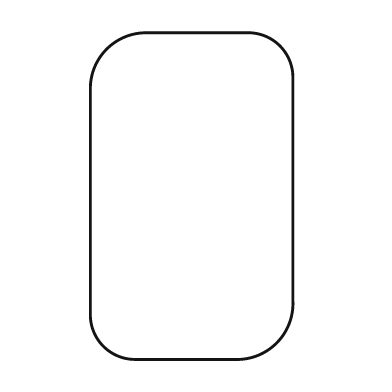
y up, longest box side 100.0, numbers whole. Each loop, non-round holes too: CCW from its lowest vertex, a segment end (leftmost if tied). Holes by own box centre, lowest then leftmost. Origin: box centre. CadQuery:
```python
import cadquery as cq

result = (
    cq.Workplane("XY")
    .moveTo(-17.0, -50.0)
    .lineTo(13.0, -50.0)
    .threePointArc((26.0, -45.0), (31.0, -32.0))
    .lineTo(31.0, 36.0)
    .threePointArc((27.0, 46.0), (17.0, 50.0))
    .lineTo(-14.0, 50.0)
    .threePointArc((-26.0, 45.0), (-31.0, 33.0))
    .lineTo(-31.0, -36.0)
    .threePointArc((-27.0, -46.0), (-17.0, -50.0))
    .close()
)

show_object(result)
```